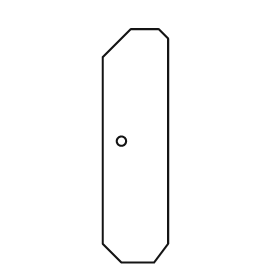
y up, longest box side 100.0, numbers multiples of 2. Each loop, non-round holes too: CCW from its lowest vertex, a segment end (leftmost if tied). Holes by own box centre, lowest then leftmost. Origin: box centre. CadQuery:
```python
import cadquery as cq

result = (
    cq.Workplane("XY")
    .moveTo(-6.0, -50.0)
    .lineTo(8.0, -50.0)
    .lineTo(14.0, -42.0)
    .lineTo(14.0, 46.0)
    .lineTo(10.0, 50.0)
    .lineTo(-2.0, 50.0)
    .lineTo(-14.0, 38.0)
    .lineTo(-14.0, -42.0)
    .close()
    .moveTo(-6.0, 2.0)
    .circle(2.0)
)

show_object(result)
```